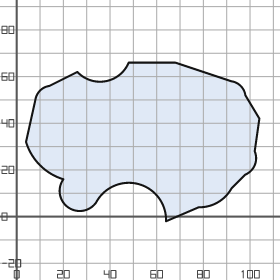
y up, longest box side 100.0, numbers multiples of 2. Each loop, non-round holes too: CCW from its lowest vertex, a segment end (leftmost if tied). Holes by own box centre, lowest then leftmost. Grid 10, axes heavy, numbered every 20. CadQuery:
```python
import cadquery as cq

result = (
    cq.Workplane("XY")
    .moveTo(64.0, -2.0)
    .lineTo(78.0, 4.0)
    .threePointArc((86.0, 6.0), (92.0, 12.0))
    .lineTo(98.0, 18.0)
    .threePointArc((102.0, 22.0), (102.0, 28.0))
    .lineTo(104.0, 42.0)
    .lineTo(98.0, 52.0)
    .threePointArc((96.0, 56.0), (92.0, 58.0))
    .lineTo(68.0, 66.0)
    .lineTo(48.0, 66.0)
    .threePointArc((38.0, 58.0), (26.0, 62.0))
    .lineTo(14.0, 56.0)
    .threePointArc((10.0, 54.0), (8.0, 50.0))
    .lineTo(4.0, 32.0)
    .threePointArc((10.0, 22.0), (20.0, 16.0))
    .threePointArc((22.0, 4.0), (34.0, 6.0))
    .threePointArc((52.0, 14.0), (64.0, -2.0))
    .close()
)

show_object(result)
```